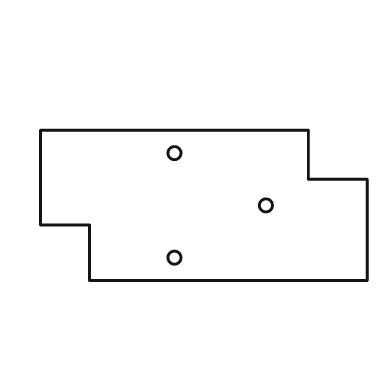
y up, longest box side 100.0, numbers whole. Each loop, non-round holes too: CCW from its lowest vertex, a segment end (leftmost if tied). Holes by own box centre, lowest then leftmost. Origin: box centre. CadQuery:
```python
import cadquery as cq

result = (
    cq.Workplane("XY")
    .moveTo(-35.0, -23.0)
    .lineTo(50.0, -23.0)
    .lineTo(50.0, 8.0)
    .lineTo(32.0, 8.0)
    .lineTo(32.0, 23.0)
    .lineTo(-50.0, 23.0)
    .lineTo(-50.0, -6.0)
    .lineTo(-35.0, -6.0)
    .close()
    .moveTo(-9.0, -16.0)
    .circle(2.0)
    .moveTo(19.0, 0.0)
    .circle(2.0)
    .moveTo(-9.0, 16.0)
    .circle(2.0)
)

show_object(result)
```